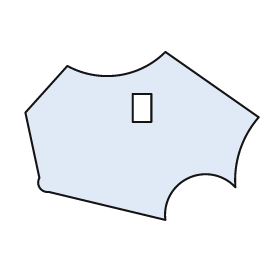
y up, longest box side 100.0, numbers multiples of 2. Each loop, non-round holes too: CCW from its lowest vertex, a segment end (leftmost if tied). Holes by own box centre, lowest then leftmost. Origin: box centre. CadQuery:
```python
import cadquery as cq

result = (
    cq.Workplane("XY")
    .moveTo(10.0, -36.0)
    .threePointArc((20.0, -18.0), (40.0, -22.0))
    .threePointArc((42.0, -6.0), (50.0, 8.0))
    .lineTo(10.0, 36.0)
    .threePointArc((-10.0, 26.0), (-32.0, 30.0))
    .lineTo(-50.0, 10.0)
    .lineTo(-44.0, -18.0)
    .threePointArc((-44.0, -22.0), (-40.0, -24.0))
    .close()
    .moveTo(-4.0, 6.0)
    .lineTo(4.0, 6.0)
    .lineTo(4.0, 18.0)
    .lineTo(-4.0, 18.0)
    .close()
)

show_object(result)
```